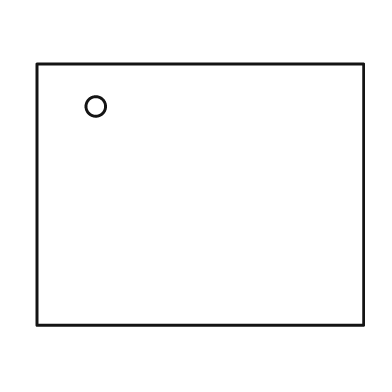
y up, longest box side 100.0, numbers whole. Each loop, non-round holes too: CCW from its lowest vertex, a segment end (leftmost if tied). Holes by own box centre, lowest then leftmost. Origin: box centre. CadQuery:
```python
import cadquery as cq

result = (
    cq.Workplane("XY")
    .moveTo(-50.0, -40.0)
    .lineTo(50.0, -40.0)
    .lineTo(50.0, 40.0)
    .lineTo(-50.0, 40.0)
    .close()
    .moveTo(-32.0, 27.0)
    .circle(3.0)
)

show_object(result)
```